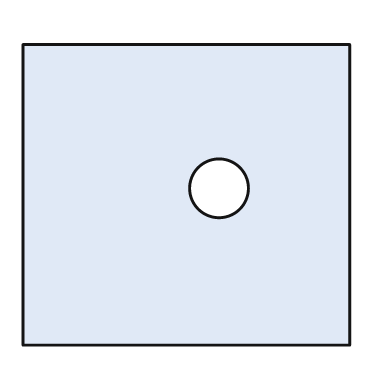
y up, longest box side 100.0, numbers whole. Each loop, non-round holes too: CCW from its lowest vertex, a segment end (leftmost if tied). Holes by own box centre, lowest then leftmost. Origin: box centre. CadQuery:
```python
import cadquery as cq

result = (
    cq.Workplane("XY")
    .moveTo(-50.0, -46.0)
    .lineTo(50.0, -46.0)
    .lineTo(50.0, 46.0)
    .lineTo(-50.0, 46.0)
    .close()
    .moveTo(10.0, 2.0)
    .circle(9.0)
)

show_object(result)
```